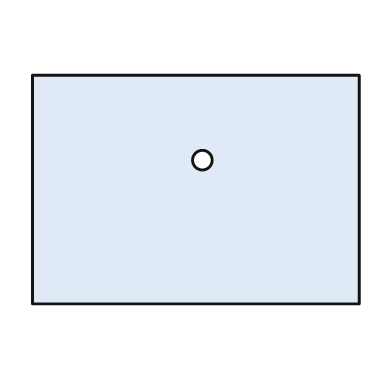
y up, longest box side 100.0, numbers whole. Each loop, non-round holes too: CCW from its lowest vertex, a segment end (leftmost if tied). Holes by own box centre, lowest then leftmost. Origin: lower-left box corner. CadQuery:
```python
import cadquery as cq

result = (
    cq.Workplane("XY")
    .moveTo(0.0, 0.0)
    .lineTo(100.0, 0.0)
    .lineTo(100.0, 70.0)
    .lineTo(0.0, 70.0)
    .close()
    .moveTo(52.0, 44.0)
    .circle(3.0)
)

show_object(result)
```